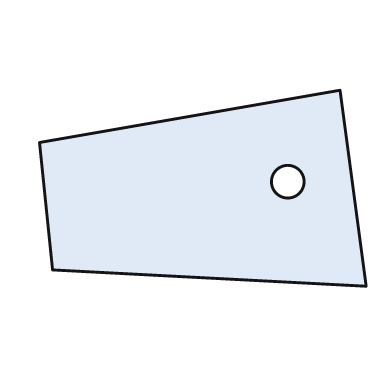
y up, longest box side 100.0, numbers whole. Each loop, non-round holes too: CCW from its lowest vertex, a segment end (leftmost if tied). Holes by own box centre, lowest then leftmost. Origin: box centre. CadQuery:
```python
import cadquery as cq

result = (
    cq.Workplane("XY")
    .moveTo(50.0, -30.0)
    .lineTo(42.0, 30.0)
    .lineTo(-50.0, 14.0)
    .lineTo(-46.0, -25.0)
    .close()
    .moveTo(26.0, 2.0)
    .circle(5.0)
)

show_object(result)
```